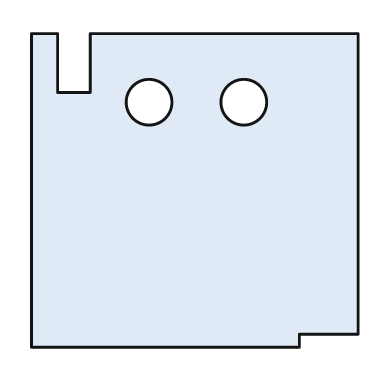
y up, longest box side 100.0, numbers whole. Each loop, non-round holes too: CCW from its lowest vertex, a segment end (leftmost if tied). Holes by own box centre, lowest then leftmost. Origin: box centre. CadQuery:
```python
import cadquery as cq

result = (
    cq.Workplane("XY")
    .moveTo(-50.0, -48.0)
    .lineTo(32.0, -48.0)
    .lineTo(32.0, -44.0)
    .lineTo(50.0, -44.0)
    .lineTo(50.0, 48.0)
    .lineTo(-32.0, 48.0)
    .lineTo(-32.0, 30.0)
    .lineTo(-42.0, 30.0)
    .lineTo(-42.0, 48.0)
    .lineTo(-50.0, 48.0)
    .close()
    .moveTo(-14.0, 27.0)
    .circle(7.0)
    .moveTo(15.0, 27.0)
    .circle(7.0)
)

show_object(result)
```